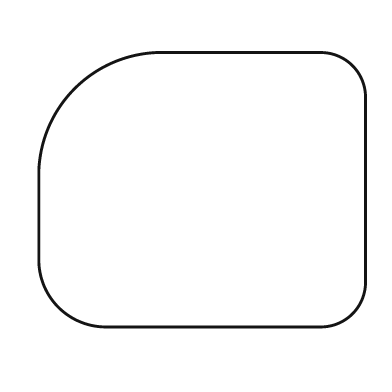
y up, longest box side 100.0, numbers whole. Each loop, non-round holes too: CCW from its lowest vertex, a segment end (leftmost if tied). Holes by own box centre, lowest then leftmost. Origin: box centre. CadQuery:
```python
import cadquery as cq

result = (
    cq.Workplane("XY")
    .moveTo(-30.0, -42.0)
    .lineTo(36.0, -42.0)
    .threePointArc((46.0, -38.0), (50.0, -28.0))
    .lineTo(50.0, 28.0)
    .threePointArc((46.0, 38.0), (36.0, 42.0))
    .lineTo(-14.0, 42.0)
    .threePointArc((-39.0, 31.0), (-50.0, 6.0))
    .lineTo(-50.0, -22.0)
    .threePointArc((-44.0, -36.0), (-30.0, -42.0))
    .close()
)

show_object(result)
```